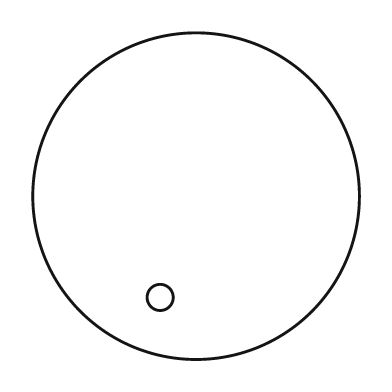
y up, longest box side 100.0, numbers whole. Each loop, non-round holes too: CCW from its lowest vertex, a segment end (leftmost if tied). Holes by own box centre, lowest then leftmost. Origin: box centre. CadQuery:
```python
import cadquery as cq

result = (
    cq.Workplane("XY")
    .moveTo(0.0, 0.0)
    .circle(50.0)
    .moveTo(-11.0, -31.0)
    .circle(4.0)
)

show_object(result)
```